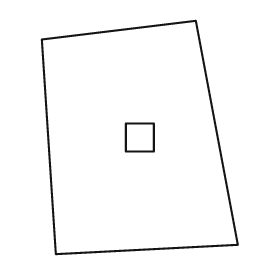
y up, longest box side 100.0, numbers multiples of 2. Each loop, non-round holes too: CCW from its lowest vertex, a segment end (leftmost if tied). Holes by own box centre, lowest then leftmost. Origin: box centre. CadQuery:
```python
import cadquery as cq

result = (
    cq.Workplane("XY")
    .moveTo(-36.0, -50.0)
    .lineTo(42.0, -46.0)
    .lineTo(24.0, 50.0)
    .lineTo(-42.0, 42.0)
    .close()
    .moveTo(-6.0, -6.0)
    .lineTo(6.0, -6.0)
    .lineTo(6.0, 6.0)
    .lineTo(-6.0, 6.0)
    .close()
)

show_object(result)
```